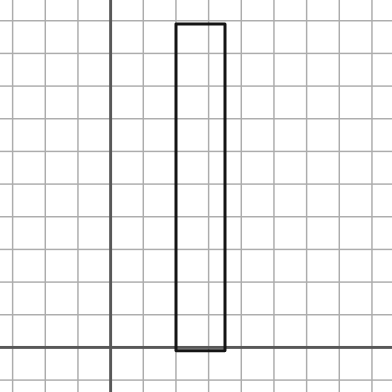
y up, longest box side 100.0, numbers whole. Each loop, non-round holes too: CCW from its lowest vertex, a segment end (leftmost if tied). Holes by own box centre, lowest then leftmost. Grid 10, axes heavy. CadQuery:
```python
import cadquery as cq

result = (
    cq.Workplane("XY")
    .moveTo(20.0, -1.0)
    .lineTo(35.0, -1.0)
    .lineTo(35.0, 99.0)
    .lineTo(20.0, 99.0)
    .close()
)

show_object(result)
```